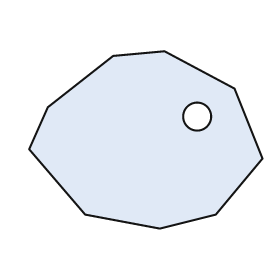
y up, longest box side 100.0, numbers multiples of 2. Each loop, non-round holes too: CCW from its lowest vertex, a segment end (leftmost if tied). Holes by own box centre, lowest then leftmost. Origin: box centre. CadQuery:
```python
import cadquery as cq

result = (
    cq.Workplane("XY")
    .moveTo(6.0, -38.0)
    .lineTo(30.0, -32.0)
    .lineTo(50.0, -8.0)
    .lineTo(38.0, 22.0)
    .lineTo(8.0, 38.0)
    .lineTo(-14.0, 36.0)
    .lineTo(-42.0, 14.0)
    .lineTo(-50.0, -4.0)
    .lineTo(-26.0, -32.0)
    .close()
    .moveTo(22.0, 10.0)
    .circle(6.0)
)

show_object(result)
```